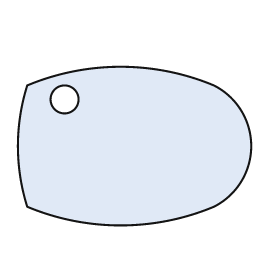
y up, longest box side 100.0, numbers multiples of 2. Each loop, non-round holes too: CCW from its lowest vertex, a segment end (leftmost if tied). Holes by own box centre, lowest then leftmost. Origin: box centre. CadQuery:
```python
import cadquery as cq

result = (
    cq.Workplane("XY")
    .moveTo(-46.0, -26.0)
    .threePointArc((-6.0, -34.0), (34.0, -26.0))
    .threePointArc((50.0, 0.0), (34.0, 26.0))
    .threePointArc((-6.0, 34.0), (-46.0, 26.0))
    .threePointArc((-50.0, 0.0), (-46.0, -26.0))
    .close()
    .moveTo(-30.0, 20.0)
    .circle(6.0)
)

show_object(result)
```